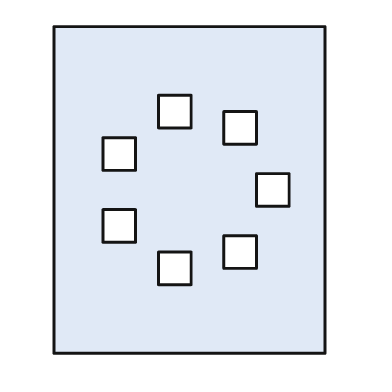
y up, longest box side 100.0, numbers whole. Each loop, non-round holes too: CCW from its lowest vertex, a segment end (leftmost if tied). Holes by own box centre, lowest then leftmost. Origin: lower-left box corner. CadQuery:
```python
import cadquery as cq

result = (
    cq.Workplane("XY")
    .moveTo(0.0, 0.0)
    .lineTo(83.0, 0.0)
    .lineTo(83.0, 100.0)
    .lineTo(0.0, 100.0)
    .close()
    .moveTo(32.0, 21.0)
    .lineTo(42.0, 21.0)
    .lineTo(42.0, 31.0)
    .lineTo(32.0, 31.0)
    .close()
    .moveTo(52.0, 26.0)
    .lineTo(62.0, 26.0)
    .lineTo(62.0, 36.0)
    .lineTo(52.0, 36.0)
    .close()
    .moveTo(15.0, 34.0)
    .lineTo(25.0, 34.0)
    .lineTo(25.0, 44.0)
    .lineTo(15.0, 44.0)
    .close()
    .moveTo(62.0, 45.0)
    .lineTo(72.0, 45.0)
    .lineTo(72.0, 55.0)
    .lineTo(62.0, 55.0)
    .close()
    .moveTo(15.0, 56.0)
    .lineTo(25.0, 56.0)
    .lineTo(25.0, 66.0)
    .lineTo(15.0, 66.0)
    .close()
    .moveTo(52.0, 64.0)
    .lineTo(62.0, 64.0)
    .lineTo(62.0, 74.0)
    .lineTo(52.0, 74.0)
    .close()
    .moveTo(32.0, 69.0)
    .lineTo(42.0, 69.0)
    .lineTo(42.0, 79.0)
    .lineTo(32.0, 79.0)
    .close()
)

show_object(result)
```